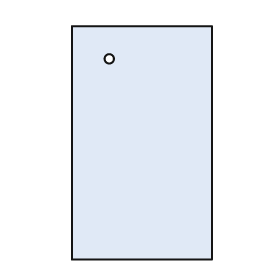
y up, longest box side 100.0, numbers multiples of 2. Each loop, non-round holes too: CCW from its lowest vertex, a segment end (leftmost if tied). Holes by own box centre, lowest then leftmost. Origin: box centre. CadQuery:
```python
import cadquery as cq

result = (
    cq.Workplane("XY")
    .moveTo(-30.0, -50.0)
    .lineTo(30.0, -50.0)
    .lineTo(30.0, 50.0)
    .lineTo(-30.0, 50.0)
    .close()
    .moveTo(-14.0, 36.0)
    .circle(2.0)
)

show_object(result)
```